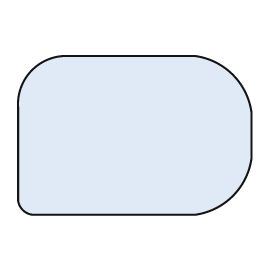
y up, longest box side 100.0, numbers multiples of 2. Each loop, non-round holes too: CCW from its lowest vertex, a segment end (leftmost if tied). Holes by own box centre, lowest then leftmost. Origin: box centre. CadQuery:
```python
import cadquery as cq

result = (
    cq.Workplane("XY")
    .moveTo(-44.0, -34.0)
    .lineTo(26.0, -34.0)
    .threePointArc((42.0, -26.0), (50.0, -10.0))
    .lineTo(50.0, 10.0)
    .threePointArc((42.0, 26.0), (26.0, 34.0))
    .lineTo(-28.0, 34.0)
    .threePointArc((-44.0, 28.0), (-50.0, 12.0))
    .lineTo(-50.0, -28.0)
    .threePointArc((-48.0, -32.0), (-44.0, -34.0))
    .close()
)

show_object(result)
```